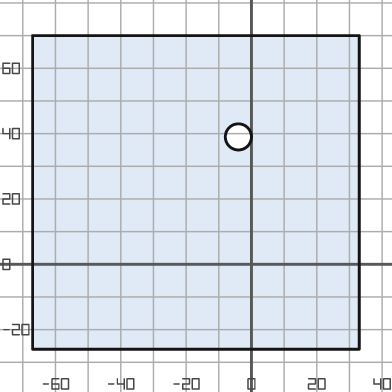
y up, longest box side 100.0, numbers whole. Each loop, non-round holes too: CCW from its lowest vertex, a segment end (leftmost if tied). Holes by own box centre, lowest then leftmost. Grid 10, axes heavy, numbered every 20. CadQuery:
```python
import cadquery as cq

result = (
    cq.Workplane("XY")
    .moveTo(-67.0, -26.0)
    .lineTo(33.0, -26.0)
    .lineTo(33.0, 70.0)
    .lineTo(-67.0, 70.0)
    .close()
    .moveTo(-4.0, 39.0)
    .circle(4.0)
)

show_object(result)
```